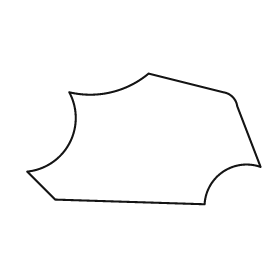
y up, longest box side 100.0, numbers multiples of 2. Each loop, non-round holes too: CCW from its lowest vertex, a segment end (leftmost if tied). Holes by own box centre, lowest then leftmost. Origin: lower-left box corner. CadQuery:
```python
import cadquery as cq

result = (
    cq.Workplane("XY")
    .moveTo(76.0, 0.0)
    .threePointArc((84.0, 14.0), (100.0, 16.0))
    .lineTo(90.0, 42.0)
    .threePointArc((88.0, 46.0), (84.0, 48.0))
    .lineTo(52.0, 56.0)
    .threePointArc((36.0, 48.0), (18.0, 48.0))
    .threePointArc((18.0, 26.0), (0.0, 14.0))
    .lineTo(12.0, 2.0)
    .close()
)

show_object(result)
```